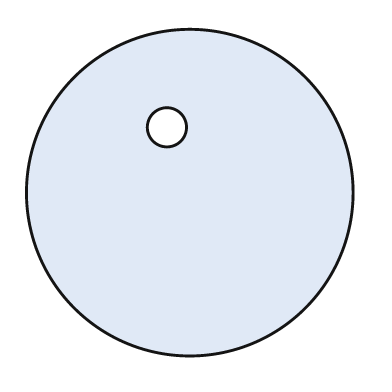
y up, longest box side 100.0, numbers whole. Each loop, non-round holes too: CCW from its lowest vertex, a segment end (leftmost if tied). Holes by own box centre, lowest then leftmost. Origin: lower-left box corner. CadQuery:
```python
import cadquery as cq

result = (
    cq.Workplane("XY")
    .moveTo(50.0, 50.0)
    .circle(50.0)
    .moveTo(43.0, 70.0)
    .circle(6.0)
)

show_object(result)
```